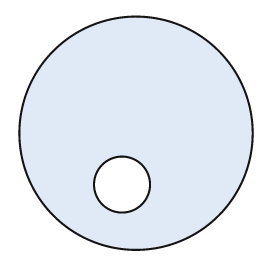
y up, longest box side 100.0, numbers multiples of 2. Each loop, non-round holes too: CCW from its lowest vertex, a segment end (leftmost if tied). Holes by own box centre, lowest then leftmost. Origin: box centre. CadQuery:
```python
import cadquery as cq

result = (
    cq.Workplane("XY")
    .moveTo(0.0, 0.0)
    .circle(50.0)
    .moveTo(-6.0, -22.0)
    .circle(12.0)
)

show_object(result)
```